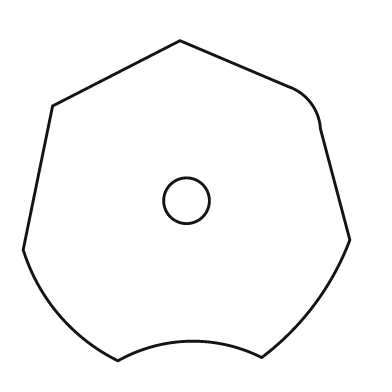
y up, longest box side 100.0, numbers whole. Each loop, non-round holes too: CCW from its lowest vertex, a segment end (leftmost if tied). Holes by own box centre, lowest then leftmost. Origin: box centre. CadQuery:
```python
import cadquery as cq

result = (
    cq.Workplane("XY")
    .moveTo(-21.0, -49.0)
    .threePointArc((1.0, -43.0), (23.0, -48.0))
    .threePointArc((39.0, -32.0), (50.0, -12.0))
    .lineTo(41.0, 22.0)
    .threePointArc((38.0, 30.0), (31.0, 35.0))
    .lineTo(-2.0, 49.0)
    .lineTo(-41.0, 29.0)
    .lineTo(-50.0, -15.0)
    .threePointArc((-39.0, -35.0), (-21.0, -49.0))
    .close()
    .moveTo(0.0, 0.0)
    .circle(7.0)
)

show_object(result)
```